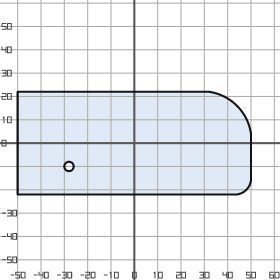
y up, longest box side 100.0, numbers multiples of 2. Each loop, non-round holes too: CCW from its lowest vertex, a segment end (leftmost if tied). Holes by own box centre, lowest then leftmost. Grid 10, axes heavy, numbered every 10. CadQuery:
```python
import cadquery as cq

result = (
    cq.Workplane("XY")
    .moveTo(-50.0, -22.0)
    .lineTo(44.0, -22.0)
    .threePointArc((48.0, -20.0), (50.0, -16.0))
    .lineTo(50.0, 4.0)
    .threePointArc((44.0, 16.0), (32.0, 22.0))
    .lineTo(-50.0, 22.0)
    .close()
    .moveTo(-28.0, -10.0)
    .circle(2.0)
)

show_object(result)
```